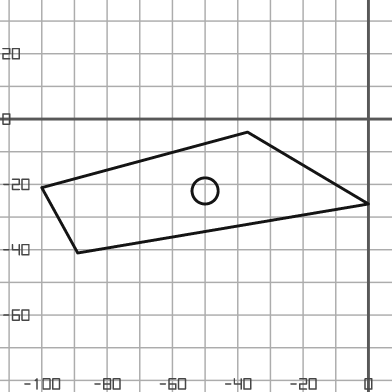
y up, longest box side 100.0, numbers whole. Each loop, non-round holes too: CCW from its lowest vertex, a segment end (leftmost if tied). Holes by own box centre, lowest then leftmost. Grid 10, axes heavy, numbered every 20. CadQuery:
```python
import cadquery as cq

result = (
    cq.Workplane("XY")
    .moveTo(-89.0, -41.0)
    .lineTo(0.0, -26.0)
    .lineTo(-37.0, -4.0)
    .lineTo(-100.0, -21.0)
    .close()
    .moveTo(-50.0, -22.0)
    .circle(4.0)
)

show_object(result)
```